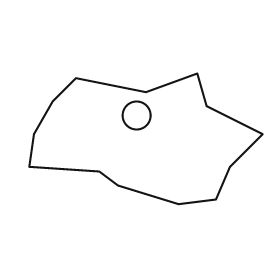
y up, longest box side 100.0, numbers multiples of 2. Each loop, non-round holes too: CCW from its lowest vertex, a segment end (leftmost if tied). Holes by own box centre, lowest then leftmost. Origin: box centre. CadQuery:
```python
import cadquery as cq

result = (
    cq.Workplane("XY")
    .moveTo(14.0, -28.0)
    .lineTo(30.0, -26.0)
    .lineTo(36.0, -12.0)
    .lineTo(50.0, 2.0)
    .lineTo(26.0, 14.0)
    .lineTo(22.0, 28.0)
    .lineTo(0.0, 20.0)
    .lineTo(-30.0, 26.0)
    .lineTo(-40.0, 16.0)
    .lineTo(-48.0, 2.0)
    .lineTo(-50.0, -12.0)
    .lineTo(-20.0, -14.0)
    .lineTo(-12.0, -20.0)
    .close()
    .moveTo(-4.0, 10.0)
    .circle(6.0)
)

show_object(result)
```